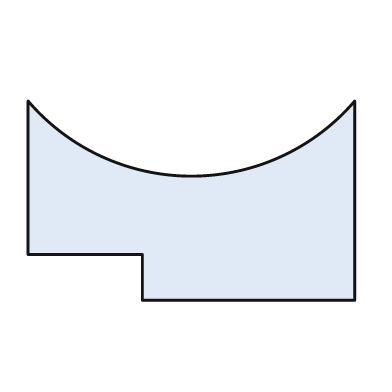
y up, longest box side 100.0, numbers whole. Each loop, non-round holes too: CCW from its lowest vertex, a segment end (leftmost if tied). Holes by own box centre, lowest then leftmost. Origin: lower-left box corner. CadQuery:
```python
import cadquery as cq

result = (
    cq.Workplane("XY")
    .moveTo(35.0, 0.0)
    .lineTo(100.0, 0.0)
    .lineTo(100.0, 61.0)
    .threePointArc((50.0, 38.0), (0.0, 61.0))
    .lineTo(0.0, 14.0)
    .lineTo(35.0, 14.0)
    .close()
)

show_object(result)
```